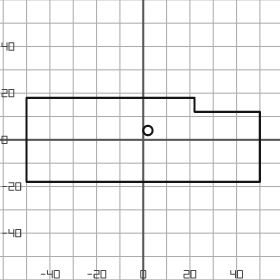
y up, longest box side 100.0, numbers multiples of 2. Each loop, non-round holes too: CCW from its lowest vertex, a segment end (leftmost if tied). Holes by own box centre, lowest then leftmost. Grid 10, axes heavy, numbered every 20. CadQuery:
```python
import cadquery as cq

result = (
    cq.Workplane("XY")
    .moveTo(-50.0, -18.0)
    .lineTo(50.0, -18.0)
    .lineTo(50.0, 12.0)
    .lineTo(22.0, 12.0)
    .lineTo(22.0, 18.0)
    .lineTo(-50.0, 18.0)
    .close()
    .moveTo(2.0, 4.0)
    .circle(2.0)
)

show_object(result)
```